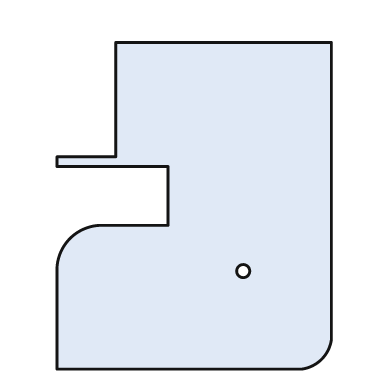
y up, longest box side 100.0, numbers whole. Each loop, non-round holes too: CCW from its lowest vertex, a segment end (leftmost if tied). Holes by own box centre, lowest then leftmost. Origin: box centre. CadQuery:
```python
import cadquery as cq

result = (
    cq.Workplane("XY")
    .moveTo(-42.0, -50.0)
    .lineTo(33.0, -50.0)
    .threePointArc((39.0, -47.0), (42.0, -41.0))
    .lineTo(42.0, 50.0)
    .lineTo(-24.0, 50.0)
    .lineTo(-24.0, 15.0)
    .lineTo(-42.0, 15.0)
    .lineTo(-42.0, 12.0)
    .lineTo(-8.0, 12.0)
    .lineTo(-8.0, -6.0)
    .lineTo(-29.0, -6.0)
    .threePointArc((-38.0, -10.0), (-42.0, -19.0))
    .close()
    .moveTo(15.0, -20.0)
    .circle(2.0)
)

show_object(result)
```